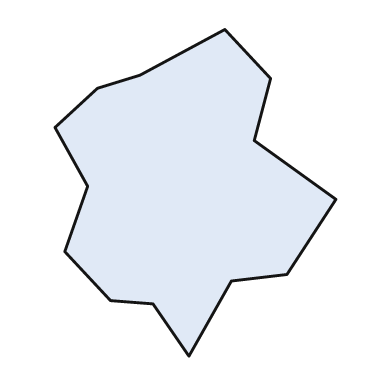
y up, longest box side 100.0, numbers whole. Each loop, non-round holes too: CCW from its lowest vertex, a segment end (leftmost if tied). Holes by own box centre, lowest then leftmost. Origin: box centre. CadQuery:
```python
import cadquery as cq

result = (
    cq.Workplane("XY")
    .moveTo(-2.0, -50.0)
    .lineTo(11.0, -27.0)
    .lineTo(28.0, -25.0)
    .lineTo(43.0, -2.0)
    .lineTo(18.0, 16.0)
    .lineTo(23.0, 35.0)
    .lineTo(9.0, 50.0)
    .lineTo(-17.0, 36.0)
    .lineTo(-30.0, 32.0)
    .lineTo(-43.0, 20.0)
    .lineTo(-33.0, 2.0)
    .lineTo(-40.0, -18.0)
    .lineTo(-26.0, -33.0)
    .lineTo(-13.0, -34.0)
    .close()
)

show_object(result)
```